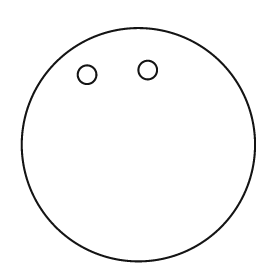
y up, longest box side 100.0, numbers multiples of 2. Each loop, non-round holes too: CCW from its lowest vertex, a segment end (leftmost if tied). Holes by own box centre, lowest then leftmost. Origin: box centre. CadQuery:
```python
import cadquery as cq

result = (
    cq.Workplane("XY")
    .moveTo(0.0, 0.0)
    .circle(50.0)
    .moveTo(-22.0, 30.0)
    .circle(4.0)
    .moveTo(4.0, 32.0)
    .circle(4.0)
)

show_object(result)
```